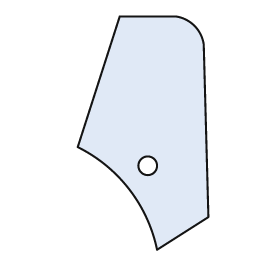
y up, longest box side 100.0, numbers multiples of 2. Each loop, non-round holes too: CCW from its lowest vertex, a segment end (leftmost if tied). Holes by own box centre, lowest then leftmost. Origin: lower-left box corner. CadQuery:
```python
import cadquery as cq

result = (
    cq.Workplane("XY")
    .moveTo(34.0, 0.0)
    .lineTo(56.0, 14.0)
    .lineTo(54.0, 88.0)
    .threePointArc((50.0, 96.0), (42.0, 100.0))
    .lineTo(18.0, 100.0)
    .lineTo(0.0, 44.0)
    .threePointArc((22.0, 26.0), (34.0, 0.0))
    .close()
    .moveTo(30.0, 36.0)
    .circle(4.0)
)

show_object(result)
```